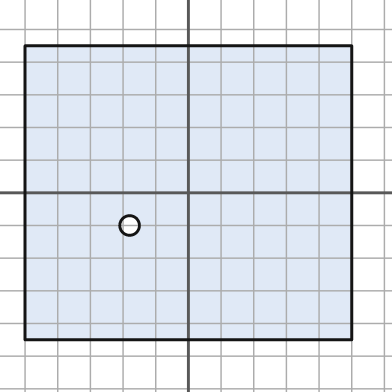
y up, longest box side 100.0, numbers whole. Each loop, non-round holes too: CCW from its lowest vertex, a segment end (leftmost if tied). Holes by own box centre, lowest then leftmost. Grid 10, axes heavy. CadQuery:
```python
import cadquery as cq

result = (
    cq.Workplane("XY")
    .moveTo(-50.0, -45.0)
    .lineTo(50.0, -45.0)
    .lineTo(50.0, 45.0)
    .lineTo(-50.0, 45.0)
    .close()
    .moveTo(-18.0, -10.0)
    .circle(3.0)
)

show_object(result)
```